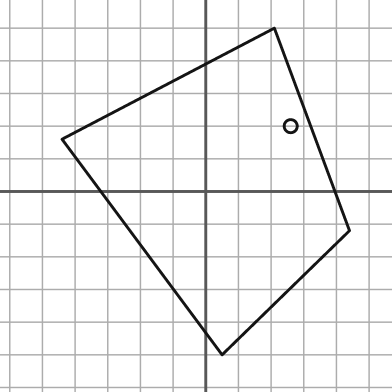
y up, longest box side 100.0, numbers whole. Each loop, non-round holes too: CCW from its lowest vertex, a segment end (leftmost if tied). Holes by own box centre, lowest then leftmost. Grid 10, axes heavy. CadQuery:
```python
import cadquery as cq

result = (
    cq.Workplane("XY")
    .moveTo(5.0, -50.0)
    .lineTo(44.0, -12.0)
    .lineTo(21.0, 50.0)
    .lineTo(-44.0, 16.0)
    .close()
    .moveTo(26.0, 20.0)
    .circle(2.0)
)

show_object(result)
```